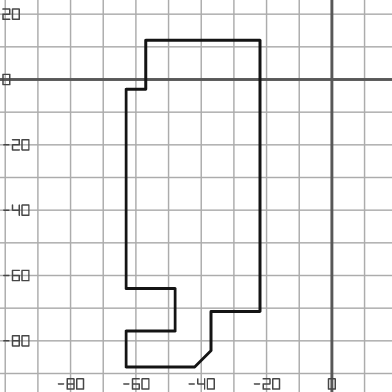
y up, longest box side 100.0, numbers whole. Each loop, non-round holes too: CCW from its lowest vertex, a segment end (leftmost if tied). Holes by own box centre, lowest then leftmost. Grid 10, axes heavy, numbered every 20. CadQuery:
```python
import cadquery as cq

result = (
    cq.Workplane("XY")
    .moveTo(-63.0, -88.0)
    .lineTo(-42.0, -88.0)
    .lineTo(-37.0, -83.0)
    .lineTo(-37.0, -71.0)
    .lineTo(-22.0, -71.0)
    .lineTo(-22.0, 12.0)
    .lineTo(-57.0, 12.0)
    .lineTo(-57.0, -3.0)
    .lineTo(-63.0, -3.0)
    .lineTo(-63.0, -64.0)
    .lineTo(-48.0, -64.0)
    .lineTo(-48.0, -77.0)
    .lineTo(-63.0, -77.0)
    .close()
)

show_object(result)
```